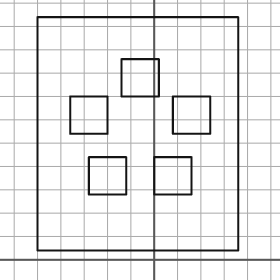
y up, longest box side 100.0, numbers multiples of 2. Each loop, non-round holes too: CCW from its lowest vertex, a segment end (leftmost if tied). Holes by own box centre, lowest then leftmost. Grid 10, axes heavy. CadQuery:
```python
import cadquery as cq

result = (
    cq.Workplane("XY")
    .moveTo(-50.0, 4.0)
    .lineTo(36.0, 4.0)
    .lineTo(36.0, 104.0)
    .lineTo(-50.0, 104.0)
    .close()
    .moveTo(-28.0, 28.0)
    .lineTo(-12.0, 28.0)
    .lineTo(-12.0, 44.0)
    .lineTo(-28.0, 44.0)
    .close()
    .moveTo(0.0, 28.0)
    .lineTo(16.0, 28.0)
    .lineTo(16.0, 44.0)
    .lineTo(0.0, 44.0)
    .close()
    .moveTo(-36.0, 54.0)
    .lineTo(-20.0, 54.0)
    .lineTo(-20.0, 70.0)
    .lineTo(-36.0, 70.0)
    .close()
    .moveTo(8.0, 54.0)
    .lineTo(24.0, 54.0)
    .lineTo(24.0, 70.0)
    .lineTo(8.0, 70.0)
    .close()
    .moveTo(-14.0, 70.0)
    .lineTo(2.0, 70.0)
    .lineTo(2.0, 86.0)
    .lineTo(-14.0, 86.0)
    .close()
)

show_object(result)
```